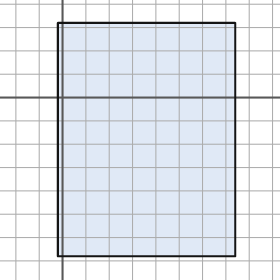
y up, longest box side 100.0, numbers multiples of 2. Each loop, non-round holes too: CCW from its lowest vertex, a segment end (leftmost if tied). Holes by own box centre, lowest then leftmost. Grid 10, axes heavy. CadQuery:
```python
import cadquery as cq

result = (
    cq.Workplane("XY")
    .moveTo(-2.0, -68.0)
    .lineTo(74.0, -68.0)
    .lineTo(74.0, 32.0)
    .lineTo(-2.0, 32.0)
    .close()
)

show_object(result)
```